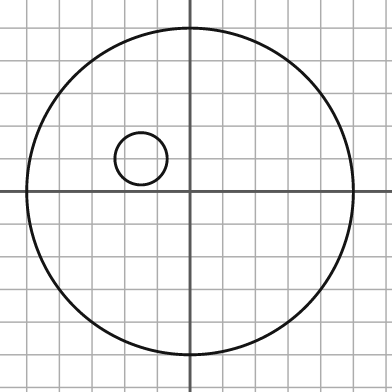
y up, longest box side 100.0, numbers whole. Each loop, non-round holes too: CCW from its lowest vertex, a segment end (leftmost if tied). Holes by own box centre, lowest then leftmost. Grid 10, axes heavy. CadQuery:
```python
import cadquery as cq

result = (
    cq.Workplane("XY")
    .moveTo(0.0, 0.0)
    .circle(50.0)
    .moveTo(-15.0, 10.0)
    .circle(8.0)
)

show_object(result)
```